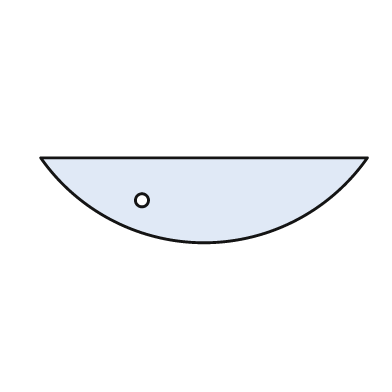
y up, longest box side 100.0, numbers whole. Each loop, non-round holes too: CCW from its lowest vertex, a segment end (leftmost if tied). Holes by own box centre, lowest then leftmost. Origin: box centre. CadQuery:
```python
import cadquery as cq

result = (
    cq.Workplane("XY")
    .moveTo(-50.0, 13.0)
    .threePointArc((0.0, -13.0), (50.0, 13.0))
    .close()
    .moveTo(-19.0, 0.0)
    .circle(2.0)
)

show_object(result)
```